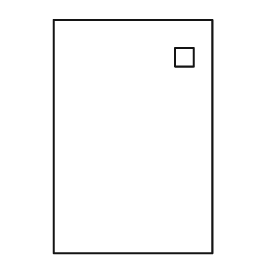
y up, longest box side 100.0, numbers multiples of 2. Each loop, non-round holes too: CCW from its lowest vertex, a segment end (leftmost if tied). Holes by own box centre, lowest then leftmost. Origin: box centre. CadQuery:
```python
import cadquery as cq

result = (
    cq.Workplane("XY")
    .moveTo(-34.0, -50.0)
    .lineTo(34.0, -50.0)
    .lineTo(34.0, 50.0)
    .lineTo(-34.0, 50.0)
    .close()
    .moveTo(18.0, 30.0)
    .lineTo(26.0, 30.0)
    .lineTo(26.0, 38.0)
    .lineTo(18.0, 38.0)
    .close()
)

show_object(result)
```